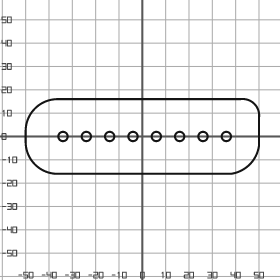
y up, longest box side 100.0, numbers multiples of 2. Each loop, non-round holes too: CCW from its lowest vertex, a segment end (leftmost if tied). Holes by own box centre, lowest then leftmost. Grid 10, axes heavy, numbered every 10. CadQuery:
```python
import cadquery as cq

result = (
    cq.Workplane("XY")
    .moveTo(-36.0, -16.0)
    .lineTo(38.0, -16.0)
    .threePointArc((46.0, -12.0), (50.0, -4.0))
    .lineTo(50.0, 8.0)
    .threePointArc((48.0, 14.0), (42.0, 16.0))
    .lineTo(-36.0, 16.0)
    .threePointArc((-46.0, 12.0), (-50.0, 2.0))
    .lineTo(-50.0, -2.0)
    .threePointArc((-46.0, -12.0), (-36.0, -16.0))
    .close()
    .moveTo(-34.0, 0.0)
    .circle(2.0)
    .moveTo(-24.0, 0.0)
    .circle(2.0)
    .moveTo(-14.0, 0.0)
    .circle(2.0)
    .moveTo(-4.0, 0.0)
    .circle(2.0)
    .moveTo(6.0, 0.0)
    .circle(2.0)
    .moveTo(16.0, 0.0)
    .circle(2.0)
    .moveTo(26.0, 0.0)
    .circle(2.0)
    .moveTo(36.0, 0.0)
    .circle(2.0)
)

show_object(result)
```